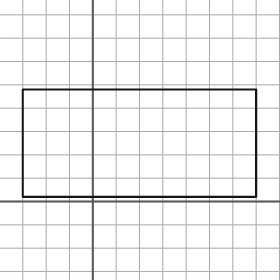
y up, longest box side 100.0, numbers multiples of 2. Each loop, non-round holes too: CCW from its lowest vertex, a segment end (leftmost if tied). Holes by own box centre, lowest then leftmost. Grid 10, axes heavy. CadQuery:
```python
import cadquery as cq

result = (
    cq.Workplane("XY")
    .moveTo(-30.0, 2.0)
    .lineTo(70.0, 2.0)
    .lineTo(70.0, 48.0)
    .lineTo(-30.0, 48.0)
    .close()
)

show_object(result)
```